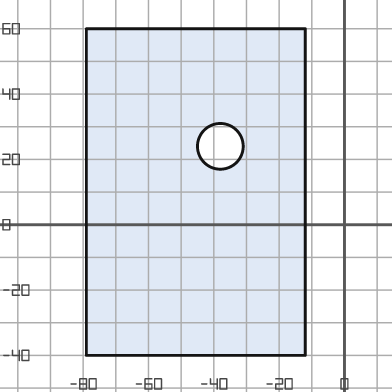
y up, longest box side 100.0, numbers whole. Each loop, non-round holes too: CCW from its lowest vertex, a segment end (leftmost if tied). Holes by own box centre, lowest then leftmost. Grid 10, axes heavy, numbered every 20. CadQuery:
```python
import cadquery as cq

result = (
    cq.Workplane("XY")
    .moveTo(-79.0, -40.0)
    .lineTo(-12.0, -40.0)
    .lineTo(-12.0, 60.0)
    .lineTo(-79.0, 60.0)
    .close()
    .moveTo(-38.0, 24.0)
    .circle(7.0)
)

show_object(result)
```